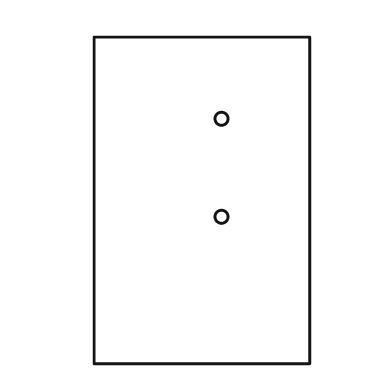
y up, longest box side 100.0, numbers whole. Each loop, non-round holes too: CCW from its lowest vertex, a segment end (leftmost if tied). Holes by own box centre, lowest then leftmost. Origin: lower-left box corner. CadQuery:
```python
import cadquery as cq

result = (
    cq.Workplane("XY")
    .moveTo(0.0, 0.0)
    .lineTo(66.0, 0.0)
    .lineTo(66.0, 100.0)
    .lineTo(0.0, 100.0)
    .close()
    .moveTo(39.0, 45.0)
    .circle(2.0)
    .moveTo(39.0, 75.0)
    .circle(2.0)
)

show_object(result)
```